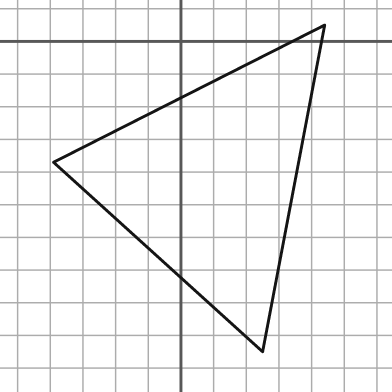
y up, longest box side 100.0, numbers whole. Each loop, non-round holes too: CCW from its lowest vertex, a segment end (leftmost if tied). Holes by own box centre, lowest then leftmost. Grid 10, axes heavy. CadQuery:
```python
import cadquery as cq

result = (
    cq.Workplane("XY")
    .moveTo(25.0, -95.0)
    .lineTo(44.0, 5.0)
    .lineTo(-39.0, -37.0)
    .close()
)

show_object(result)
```